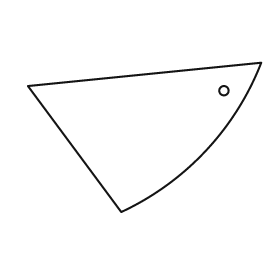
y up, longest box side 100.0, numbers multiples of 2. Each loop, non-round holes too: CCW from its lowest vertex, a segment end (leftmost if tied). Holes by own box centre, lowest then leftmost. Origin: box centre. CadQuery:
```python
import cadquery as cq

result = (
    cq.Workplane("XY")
    .moveTo(-10.0, -32.0)
    .threePointArc((26.0, -6.0), (50.0, 32.0))
    .lineTo(-50.0, 22.0)
    .close()
    .moveTo(34.0, 20.0)
    .circle(2.0)
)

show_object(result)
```